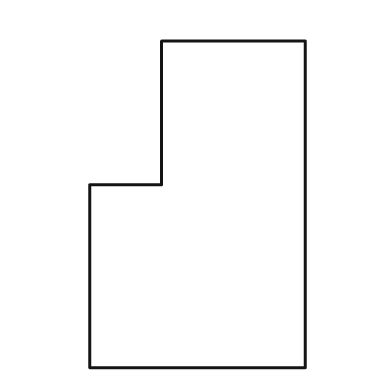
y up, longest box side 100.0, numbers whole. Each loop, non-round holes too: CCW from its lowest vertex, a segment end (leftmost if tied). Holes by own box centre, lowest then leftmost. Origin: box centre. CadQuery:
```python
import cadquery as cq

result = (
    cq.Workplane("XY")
    .moveTo(-33.0, -50.0)
    .lineTo(33.0, -50.0)
    .lineTo(33.0, 50.0)
    .lineTo(-11.0, 50.0)
    .lineTo(-11.0, 6.0)
    .lineTo(-33.0, 6.0)
    .close()
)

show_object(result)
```